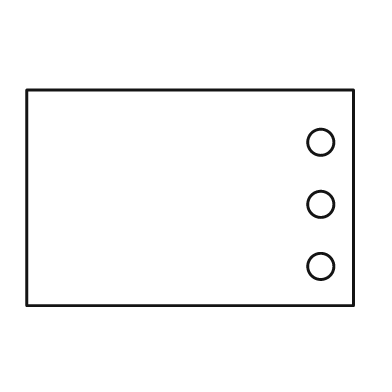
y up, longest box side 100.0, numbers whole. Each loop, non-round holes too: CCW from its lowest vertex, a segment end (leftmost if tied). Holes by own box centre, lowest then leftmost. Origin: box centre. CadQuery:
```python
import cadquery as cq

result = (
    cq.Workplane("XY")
    .moveTo(-50.0, -33.0)
    .lineTo(50.0, -33.0)
    .lineTo(50.0, 33.0)
    .lineTo(-50.0, 33.0)
    .close()
    .moveTo(40.0, -21.0)
    .circle(4.0)
    .moveTo(40.0, -2.0)
    .circle(4.0)
    .moveTo(40.0, 17.0)
    .circle(4.0)
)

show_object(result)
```